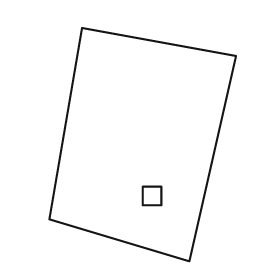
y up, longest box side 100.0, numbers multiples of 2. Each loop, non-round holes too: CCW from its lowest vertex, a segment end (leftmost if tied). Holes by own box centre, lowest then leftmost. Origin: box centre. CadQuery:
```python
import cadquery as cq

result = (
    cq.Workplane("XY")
    .moveTo(20.0, -50.0)
    .lineTo(40.0, 38.0)
    .lineTo(-26.0, 50.0)
    .lineTo(-40.0, -32.0)
    .close()
    .moveTo(0.0, -26.0)
    .lineTo(8.0, -26.0)
    .lineTo(8.0, -18.0)
    .lineTo(0.0, -18.0)
    .close()
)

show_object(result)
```